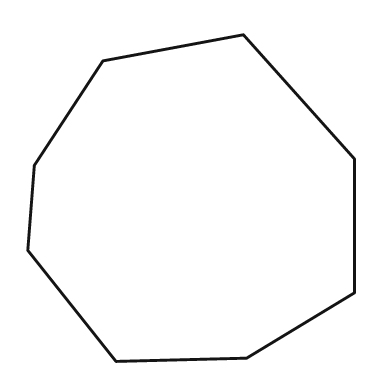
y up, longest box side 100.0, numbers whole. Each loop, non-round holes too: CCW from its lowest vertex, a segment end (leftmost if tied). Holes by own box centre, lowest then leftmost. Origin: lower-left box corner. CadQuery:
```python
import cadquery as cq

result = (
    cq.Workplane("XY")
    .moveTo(27.0, 0.0)
    .lineTo(67.0, 1.0)
    .lineTo(100.0, 21.0)
    .lineTo(100.0, 62.0)
    .lineTo(66.0, 100.0)
    .lineTo(23.0, 92.0)
    .lineTo(2.0, 60.0)
    .lineTo(0.0, 34.0)
    .close()
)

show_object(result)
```